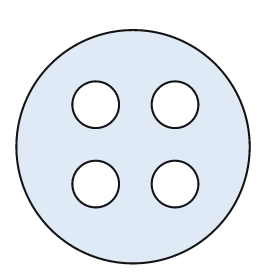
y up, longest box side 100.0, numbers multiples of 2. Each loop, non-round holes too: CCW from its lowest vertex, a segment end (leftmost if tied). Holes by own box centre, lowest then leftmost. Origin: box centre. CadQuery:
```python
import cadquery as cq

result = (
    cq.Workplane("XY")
    .moveTo(0.0, 0.0)
    .circle(50.0)
    .moveTo(-16.0, -16.0)
    .circle(10.0)
    .moveTo(18.0, -16.0)
    .circle(10.0)
    .moveTo(-16.0, 18.0)
    .circle(10.0)
    .moveTo(18.0, 18.0)
    .circle(10.0)
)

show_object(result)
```